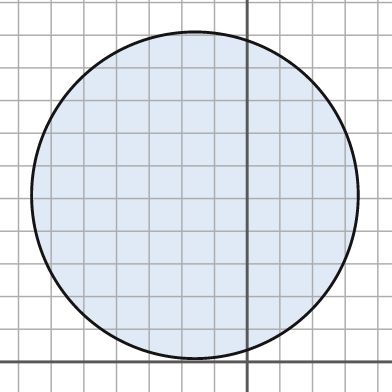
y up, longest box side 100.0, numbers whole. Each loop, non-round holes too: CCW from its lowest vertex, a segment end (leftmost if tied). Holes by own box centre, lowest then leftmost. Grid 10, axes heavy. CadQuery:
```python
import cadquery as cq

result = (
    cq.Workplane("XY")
    .moveTo(-16.0, 51.0)
    .circle(50.0)
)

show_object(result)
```